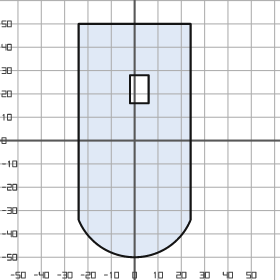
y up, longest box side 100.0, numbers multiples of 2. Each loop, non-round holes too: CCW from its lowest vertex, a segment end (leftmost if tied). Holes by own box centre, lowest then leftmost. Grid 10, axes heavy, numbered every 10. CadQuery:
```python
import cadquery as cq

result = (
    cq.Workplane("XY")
    .moveTo(-24.0, -34.0)
    .threePointArc((0.0, -50.0), (24.0, -34.0))
    .lineTo(24.0, 50.0)
    .lineTo(-24.0, 50.0)
    .close()
    .moveTo(-2.0, 16.0)
    .lineTo(6.0, 16.0)
    .lineTo(6.0, 28.0)
    .lineTo(-2.0, 28.0)
    .close()
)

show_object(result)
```